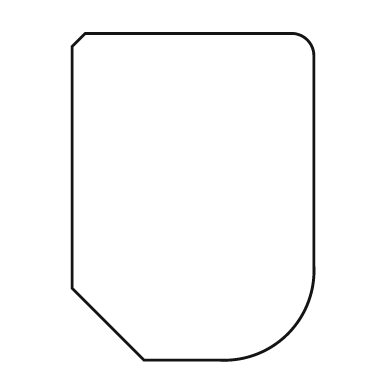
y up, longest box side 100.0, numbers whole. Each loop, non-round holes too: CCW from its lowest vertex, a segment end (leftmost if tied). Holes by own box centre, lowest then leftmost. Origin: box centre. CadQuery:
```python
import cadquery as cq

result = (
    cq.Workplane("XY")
    .moveTo(-15.0, -50.0)
    .lineTo(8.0, -50.0)
    .threePointArc((29.0, -42.0), (37.0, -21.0))
    .lineTo(37.0, 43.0)
    .threePointArc((35.0, 48.0), (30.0, 50.0))
    .lineTo(-33.0, 50.0)
    .lineTo(-37.0, 46.0)
    .lineTo(-37.0, -28.0)
    .close()
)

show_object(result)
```